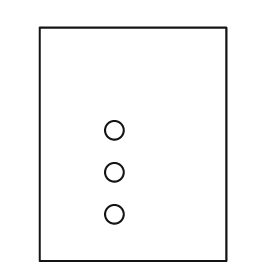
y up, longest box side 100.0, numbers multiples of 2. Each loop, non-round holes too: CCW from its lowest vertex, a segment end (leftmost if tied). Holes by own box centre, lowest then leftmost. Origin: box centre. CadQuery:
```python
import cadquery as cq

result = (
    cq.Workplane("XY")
    .moveTo(-40.0, -50.0)
    .lineTo(40.0, -50.0)
    .lineTo(40.0, 50.0)
    .lineTo(-40.0, 50.0)
    .close()
    .moveTo(-8.0, -30.0)
    .circle(4.0)
    .moveTo(-8.0, -12.0)
    .circle(4.0)
    .moveTo(-8.0, 6.0)
    .circle(4.0)
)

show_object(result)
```